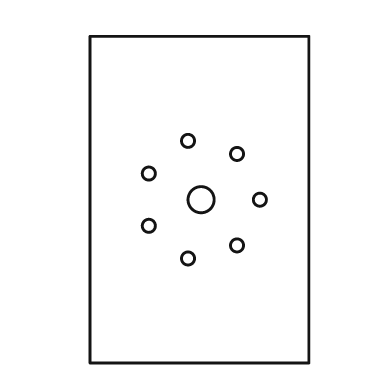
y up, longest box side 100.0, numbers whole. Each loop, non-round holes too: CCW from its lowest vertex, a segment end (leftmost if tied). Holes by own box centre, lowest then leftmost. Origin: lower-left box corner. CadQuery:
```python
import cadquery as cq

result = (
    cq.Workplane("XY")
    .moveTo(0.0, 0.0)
    .lineTo(67.0, 0.0)
    .lineTo(67.0, 100.0)
    .lineTo(0.0, 100.0)
    .close()
    .moveTo(30.0, 32.0)
    .circle(2.0)
    .moveTo(45.0, 36.0)
    .circle(2.0)
    .moveTo(18.0, 42.0)
    .circle(2.0)
    .moveTo(34.0, 50.0)
    .circle(4.0)
    .moveTo(52.0, 50.0)
    .circle(2.0)
    .moveTo(18.0, 58.0)
    .circle(2.0)
    .moveTo(45.0, 64.0)
    .circle(2.0)
    .moveTo(30.0, 68.0)
    .circle(2.0)
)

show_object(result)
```